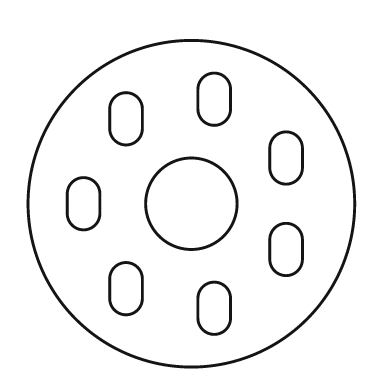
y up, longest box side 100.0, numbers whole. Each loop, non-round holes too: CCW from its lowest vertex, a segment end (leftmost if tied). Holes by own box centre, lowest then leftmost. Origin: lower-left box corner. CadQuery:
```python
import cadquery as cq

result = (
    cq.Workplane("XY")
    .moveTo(50.0, 50.0)
    .circle(50.0)
    .moveTo(52.0, 15.0)
    .threePointArc((57.0, 10.0), (62.0, 15.0))
    .lineTo(62.0, 21.0)
    .threePointArc((57.0, 26.0), (52.0, 21.0))
    .close()
    .moveTo(25.0, 21.0)
    .threePointArc((30.0, 16.0), (35.0, 21.0))
    .lineTo(35.0, 27.0)
    .threePointArc((30.0, 32.0), (25.0, 27.0))
    .close()
    .moveTo(74.0, 33.0)
    .threePointArc((79.0, 28.0), (84.0, 33.0))
    .lineTo(84.0, 39.0)
    .threePointArc((79.0, 44.0), (74.0, 39.0))
    .close()
    .moveTo(12.0, 47.0)
    .threePointArc((17.0, 42.0), (22.0, 47.0))
    .lineTo(22.0, 53.0)
    .threePointArc((17.0, 58.0), (12.0, 53.0))
    .close()
    .moveTo(50.0, 50.0)
    .circle(14.0)
    .moveTo(74.0, 61.0)
    .threePointArc((79.0, 56.0), (84.0, 61.0))
    .lineTo(84.0, 67.0)
    .threePointArc((79.0, 72.0), (74.0, 67.0))
    .close()
    .moveTo(25.0, 73.0)
    .threePointArc((30.0, 68.0), (35.0, 73.0))
    .lineTo(35.0, 79.0)
    .threePointArc((30.0, 84.0), (25.0, 79.0))
    .close()
    .moveTo(52.0, 79.0)
    .threePointArc((57.0, 74.0), (62.0, 79.0))
    .lineTo(62.0, 85.0)
    .threePointArc((57.0, 90.0), (52.0, 85.0))
    .close()
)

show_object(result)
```